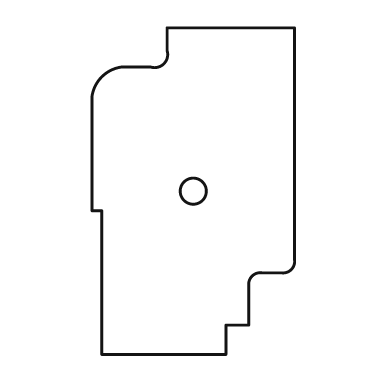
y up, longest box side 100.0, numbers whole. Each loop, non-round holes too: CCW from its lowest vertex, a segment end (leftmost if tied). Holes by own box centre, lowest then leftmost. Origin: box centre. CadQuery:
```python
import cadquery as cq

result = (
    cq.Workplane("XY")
    .moveTo(-28.0, -50.0)
    .lineTo(10.0, -50.0)
    .lineTo(10.0, -41.0)
    .lineTo(17.0, -41.0)
    .lineTo(17.0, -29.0)
    .threePointArc((18.0, -26.0), (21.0, -25.0))
    .lineTo(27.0, -25.0)
    .threePointArc((30.0, -24.0), (31.0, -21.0))
    .lineTo(31.0, 50.0)
    .lineTo(-8.0, 50.0)
    .lineTo(-8.0, 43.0)
    .threePointArc((-9.0, 39.0), (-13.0, 38.0))
    .lineTo(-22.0, 38.0)
    .threePointArc((-28.0, 35.0), (-31.0, 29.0))
    .lineTo(-31.0, -6.0)
    .lineTo(-28.0, -6.0)
    .close()
    .moveTo(0.0, 0.0)
    .circle(4.0)
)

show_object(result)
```